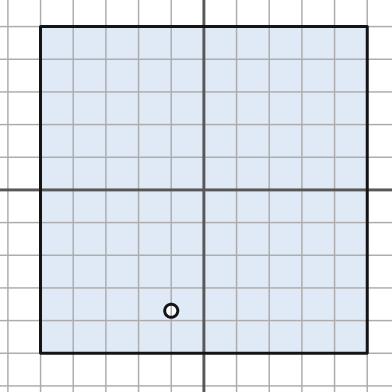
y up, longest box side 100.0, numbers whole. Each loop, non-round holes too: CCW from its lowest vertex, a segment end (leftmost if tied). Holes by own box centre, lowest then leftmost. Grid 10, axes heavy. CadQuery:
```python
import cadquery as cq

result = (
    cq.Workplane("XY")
    .moveTo(-50.0, -50.0)
    .lineTo(50.0, -50.0)
    .lineTo(50.0, 50.0)
    .lineTo(-50.0, 50.0)
    .close()
    .moveTo(-10.0, -37.0)
    .circle(2.0)
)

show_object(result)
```